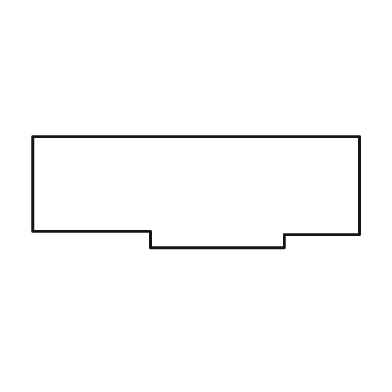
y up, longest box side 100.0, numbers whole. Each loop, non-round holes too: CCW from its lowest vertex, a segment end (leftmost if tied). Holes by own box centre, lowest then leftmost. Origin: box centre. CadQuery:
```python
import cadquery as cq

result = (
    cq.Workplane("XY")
    .moveTo(-14.0, -17.0)
    .lineTo(27.0, -17.0)
    .lineTo(27.0, -13.0)
    .lineTo(50.0, -13.0)
    .lineTo(50.0, 17.0)
    .lineTo(-50.0, 17.0)
    .lineTo(-50.0, -12.0)
    .lineTo(-14.0, -12.0)
    .close()
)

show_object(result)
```